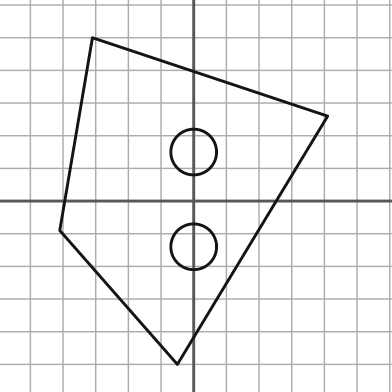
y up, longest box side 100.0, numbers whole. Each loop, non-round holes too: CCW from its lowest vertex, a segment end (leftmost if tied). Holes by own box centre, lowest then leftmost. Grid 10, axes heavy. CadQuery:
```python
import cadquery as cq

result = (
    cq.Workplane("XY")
    .moveTo(-5.0, -50.0)
    .lineTo(41.0, 26.0)
    .lineTo(-31.0, 50.0)
    .lineTo(-41.0, -9.0)
    .close()
    .moveTo(0.0, -14.0)
    .circle(7.0)
    .moveTo(0.0, 15.0)
    .circle(7.0)
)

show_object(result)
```